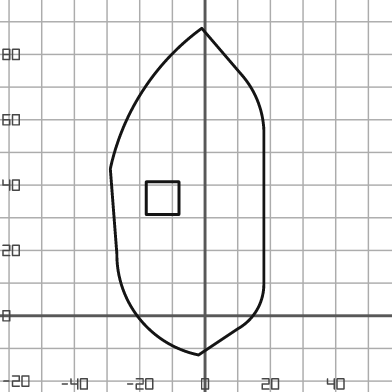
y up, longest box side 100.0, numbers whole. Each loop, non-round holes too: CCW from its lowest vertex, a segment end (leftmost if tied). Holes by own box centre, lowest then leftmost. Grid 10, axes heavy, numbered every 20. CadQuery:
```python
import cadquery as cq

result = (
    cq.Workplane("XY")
    .moveTo(-2.0, -12.0)
    .lineTo(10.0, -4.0)
    .threePointArc((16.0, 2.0), (18.0, 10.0))
    .lineTo(18.0, 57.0)
    .threePointArc((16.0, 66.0), (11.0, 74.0))
    .lineTo(-1.0, 88.0)
    .threePointArc((-19.0, 69.0), (-29.0, 45.0))
    .lineTo(-27.0, 19.0)
    .threePointArc((-20.0, -1.0), (-2.0, -12.0))
    .close()
    .moveTo(-18.0, 31.0)
    .lineTo(-8.0, 31.0)
    .lineTo(-8.0, 41.0)
    .lineTo(-18.0, 41.0)
    .close()
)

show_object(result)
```